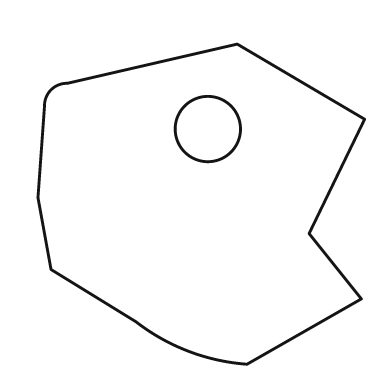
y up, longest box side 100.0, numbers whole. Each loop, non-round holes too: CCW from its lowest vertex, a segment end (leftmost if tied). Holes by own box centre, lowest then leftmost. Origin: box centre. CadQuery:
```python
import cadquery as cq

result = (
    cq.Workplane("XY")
    .moveTo(14.0, -49.0)
    .lineTo(49.0, -29.0)
    .lineTo(33.0, -9.0)
    .lineTo(50.0, 26.0)
    .lineTo(11.0, 49.0)
    .lineTo(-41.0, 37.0)
    .threePointArc((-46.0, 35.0), (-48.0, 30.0))
    .lineTo(-50.0, 2.0)
    .lineTo(-46.0, -20.0)
    .lineTo(-20.0, -36.0)
    .threePointArc((-4.0, -45.0), (14.0, -49.0))
    .close()
    .moveTo(2.0, 23.0)
    .circle(10.0)
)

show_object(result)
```